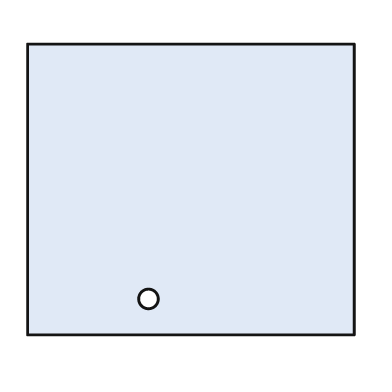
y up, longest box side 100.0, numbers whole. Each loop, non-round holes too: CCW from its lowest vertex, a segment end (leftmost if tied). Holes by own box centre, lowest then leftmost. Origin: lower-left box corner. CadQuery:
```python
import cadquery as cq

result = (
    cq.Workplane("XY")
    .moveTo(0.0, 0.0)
    .lineTo(100.0, 0.0)
    .lineTo(100.0, 89.0)
    .lineTo(0.0, 89.0)
    .close()
    .moveTo(37.0, 11.0)
    .circle(3.0)
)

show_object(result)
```